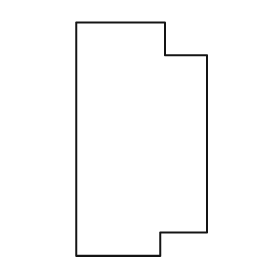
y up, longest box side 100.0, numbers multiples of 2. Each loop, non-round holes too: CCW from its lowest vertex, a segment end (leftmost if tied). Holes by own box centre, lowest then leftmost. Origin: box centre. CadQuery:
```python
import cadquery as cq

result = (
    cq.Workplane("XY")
    .moveTo(-28.0, -50.0)
    .lineTo(8.0, -50.0)
    .lineTo(8.0, -40.0)
    .lineTo(28.0, -40.0)
    .lineTo(28.0, 36.0)
    .lineTo(10.0, 36.0)
    .lineTo(10.0, 50.0)
    .lineTo(-28.0, 50.0)
    .close()
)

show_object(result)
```